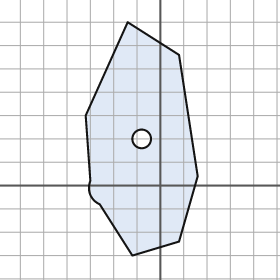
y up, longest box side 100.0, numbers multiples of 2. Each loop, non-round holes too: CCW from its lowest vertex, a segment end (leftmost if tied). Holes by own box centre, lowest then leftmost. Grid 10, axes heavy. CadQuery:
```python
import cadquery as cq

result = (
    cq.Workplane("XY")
    .moveTo(-12.0, -30.0)
    .lineTo(8.0, -24.0)
    .lineTo(16.0, 4.0)
    .lineTo(8.0, 56.0)
    .lineTo(-14.0, 70.0)
    .lineTo(-32.0, 30.0)
    .lineTo(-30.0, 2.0)
    .threePointArc((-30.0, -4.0), (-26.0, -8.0))
    .close()
    .moveTo(-8.0, 20.0)
    .circle(4.0)
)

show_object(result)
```